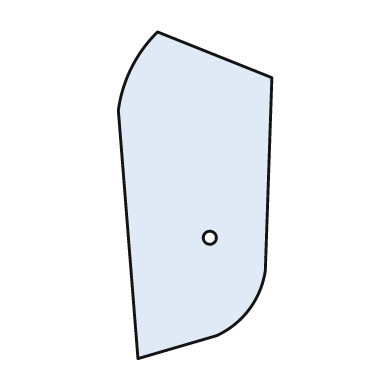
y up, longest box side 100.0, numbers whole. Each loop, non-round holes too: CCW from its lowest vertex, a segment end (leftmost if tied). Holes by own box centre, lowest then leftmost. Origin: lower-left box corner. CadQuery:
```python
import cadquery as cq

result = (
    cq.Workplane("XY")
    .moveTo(6.0, 0.0)
    .lineTo(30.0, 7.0)
    .threePointArc((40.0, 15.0), (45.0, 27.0))
    .lineTo(47.0, 86.0)
    .lineTo(12.0, 100.0)
    .threePointArc((4.0, 89.0), (0.0, 76.0))
    .close()
    .moveTo(28.0, 37.0)
    .circle(2.0)
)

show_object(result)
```